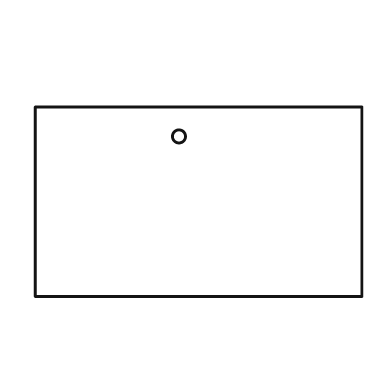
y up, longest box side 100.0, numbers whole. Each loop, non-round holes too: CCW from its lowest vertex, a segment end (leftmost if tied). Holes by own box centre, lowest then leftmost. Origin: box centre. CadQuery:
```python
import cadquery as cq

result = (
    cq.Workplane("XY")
    .moveTo(-50.0, -29.0)
    .lineTo(50.0, -29.0)
    .lineTo(50.0, 29.0)
    .lineTo(-50.0, 29.0)
    .close()
    .moveTo(-6.0, 20.0)
    .circle(2.0)
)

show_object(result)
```